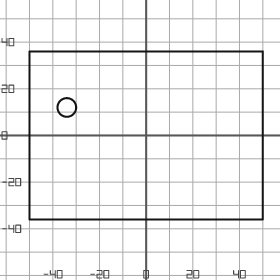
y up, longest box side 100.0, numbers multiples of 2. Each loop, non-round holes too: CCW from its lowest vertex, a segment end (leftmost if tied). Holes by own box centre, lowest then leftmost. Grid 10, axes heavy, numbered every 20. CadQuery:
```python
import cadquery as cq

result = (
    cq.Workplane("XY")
    .moveTo(-50.0, -36.0)
    .lineTo(50.0, -36.0)
    .lineTo(50.0, 36.0)
    .lineTo(-50.0, 36.0)
    .close()
    .moveTo(-34.0, 12.0)
    .circle(4.0)
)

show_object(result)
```